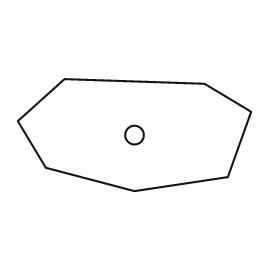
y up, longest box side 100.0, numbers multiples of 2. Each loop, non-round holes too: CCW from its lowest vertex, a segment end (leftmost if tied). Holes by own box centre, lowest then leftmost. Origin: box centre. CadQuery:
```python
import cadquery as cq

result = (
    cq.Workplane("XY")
    .moveTo(0.0, -24.0)
    .lineTo(40.0, -18.0)
    .lineTo(50.0, 10.0)
    .lineTo(30.0, 22.0)
    .lineTo(-30.0, 24.0)
    .lineTo(-50.0, 6.0)
    .lineTo(-38.0, -14.0)
    .close()
    .moveTo(0.0, 0.0)
    .circle(4.0)
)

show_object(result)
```